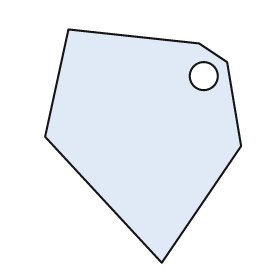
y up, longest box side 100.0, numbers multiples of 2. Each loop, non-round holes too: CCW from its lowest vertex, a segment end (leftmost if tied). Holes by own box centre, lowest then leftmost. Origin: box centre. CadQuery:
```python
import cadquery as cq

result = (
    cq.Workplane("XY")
    .moveTo(8.0, -50.0)
    .lineTo(42.0, 0.0)
    .lineTo(36.0, 36.0)
    .lineTo(24.0, 44.0)
    .lineTo(-32.0, 50.0)
    .lineTo(-42.0, 4.0)
    .close()
    .moveTo(26.0, 30.0)
    .circle(6.0)
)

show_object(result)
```